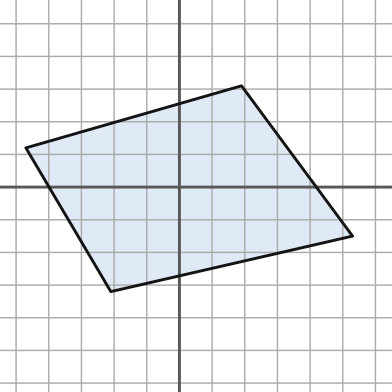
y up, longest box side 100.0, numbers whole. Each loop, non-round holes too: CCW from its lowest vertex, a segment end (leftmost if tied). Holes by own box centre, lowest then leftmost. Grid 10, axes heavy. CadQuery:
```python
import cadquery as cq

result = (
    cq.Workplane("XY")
    .moveTo(-21.0, -32.0)
    .lineTo(53.0, -15.0)
    .lineTo(19.0, 31.0)
    .lineTo(-47.0, 12.0)
    .close()
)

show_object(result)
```